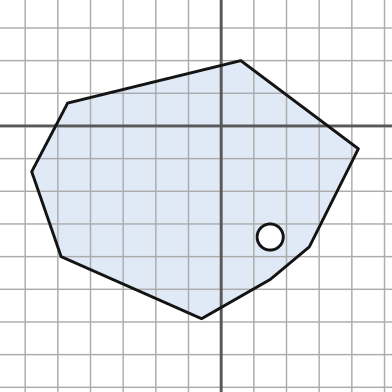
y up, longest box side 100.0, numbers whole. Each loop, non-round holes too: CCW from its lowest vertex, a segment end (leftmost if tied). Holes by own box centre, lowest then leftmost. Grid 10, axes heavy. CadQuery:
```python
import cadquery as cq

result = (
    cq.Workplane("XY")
    .moveTo(-6.0, -59.0)
    .lineTo(15.0, -47.0)
    .lineTo(27.0, -37.0)
    .lineTo(42.0, -7.0)
    .lineTo(6.0, 20.0)
    .lineTo(-47.0, 7.0)
    .lineTo(-58.0, -14.0)
    .lineTo(-49.0, -40.0)
    .close()
    .moveTo(15.0, -34.0)
    .circle(4.0)
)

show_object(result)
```